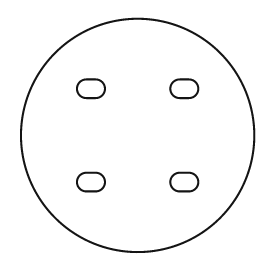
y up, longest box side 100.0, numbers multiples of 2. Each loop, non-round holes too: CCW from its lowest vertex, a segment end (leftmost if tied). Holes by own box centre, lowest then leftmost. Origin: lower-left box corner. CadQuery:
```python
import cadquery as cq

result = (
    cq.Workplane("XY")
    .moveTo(50.0, 50.0)
    .circle(50.0)
    .moveTo(28.0, 26.0)
    .lineTo(32.0, 26.0)
    .threePointArc((36.0, 30.0), (32.0, 34.0))
    .lineTo(28.0, 34.0)
    .threePointArc((24.0, 30.0), (28.0, 26.0))
    .close()
    .moveTo(68.0, 26.0)
    .lineTo(72.0, 26.0)
    .threePointArc((76.0, 30.0), (72.0, 34.0))
    .lineTo(68.0, 34.0)
    .threePointArc((64.0, 30.0), (68.0, 26.0))
    .close()
    .moveTo(28.0, 66.0)
    .lineTo(32.0, 66.0)
    .threePointArc((36.0, 70.0), (32.0, 74.0))
    .lineTo(28.0, 74.0)
    .threePointArc((24.0, 70.0), (28.0, 66.0))
    .close()
    .moveTo(68.0, 66.0)
    .lineTo(72.0, 66.0)
    .threePointArc((76.0, 70.0), (72.0, 74.0))
    .lineTo(68.0, 74.0)
    .threePointArc((64.0, 70.0), (68.0, 66.0))
    .close()
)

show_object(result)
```